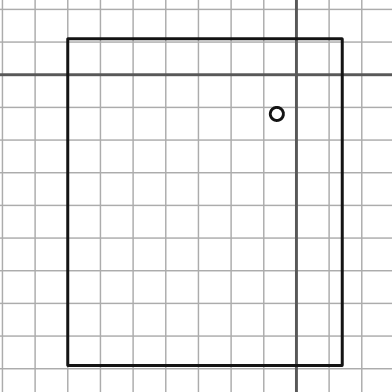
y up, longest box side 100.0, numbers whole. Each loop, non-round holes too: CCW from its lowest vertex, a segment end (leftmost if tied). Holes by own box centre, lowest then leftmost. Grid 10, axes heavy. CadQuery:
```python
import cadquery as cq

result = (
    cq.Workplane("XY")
    .moveTo(-70.0, -89.0)
    .lineTo(14.0, -89.0)
    .lineTo(14.0, 11.0)
    .lineTo(-70.0, 11.0)
    .close()
    .moveTo(-6.0, -12.0)
    .circle(2.0)
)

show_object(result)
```